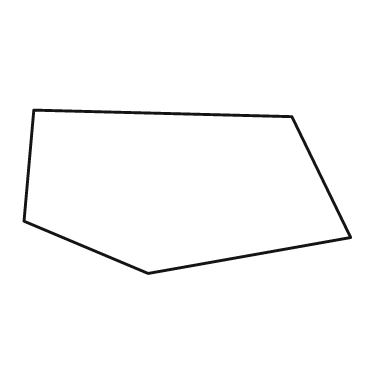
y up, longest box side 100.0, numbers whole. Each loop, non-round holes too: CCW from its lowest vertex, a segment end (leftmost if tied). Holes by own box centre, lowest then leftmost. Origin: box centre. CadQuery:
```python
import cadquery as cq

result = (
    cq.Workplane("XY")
    .moveTo(-12.0, -25.0)
    .lineTo(50.0, -14.0)
    .lineTo(32.0, 23.0)
    .lineTo(-47.0, 25.0)
    .lineTo(-50.0, -9.0)
    .close()
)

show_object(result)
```